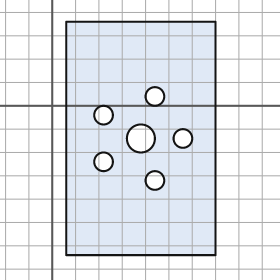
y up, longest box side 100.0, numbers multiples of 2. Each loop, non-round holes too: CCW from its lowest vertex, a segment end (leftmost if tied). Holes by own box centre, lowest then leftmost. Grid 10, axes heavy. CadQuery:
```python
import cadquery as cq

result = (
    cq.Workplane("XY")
    .moveTo(6.0, -64.0)
    .lineTo(70.0, -64.0)
    .lineTo(70.0, 36.0)
    .lineTo(6.0, 36.0)
    .close()
    .moveTo(44.0, -32.0)
    .circle(4.0)
    .moveTo(22.0, -24.0)
    .circle(4.0)
    .moveTo(38.0, -14.0)
    .circle(6.0)
    .moveTo(56.0, -14.0)
    .circle(4.0)
    .moveTo(22.0, -4.0)
    .circle(4.0)
    .moveTo(44.0, 4.0)
    .circle(4.0)
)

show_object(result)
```